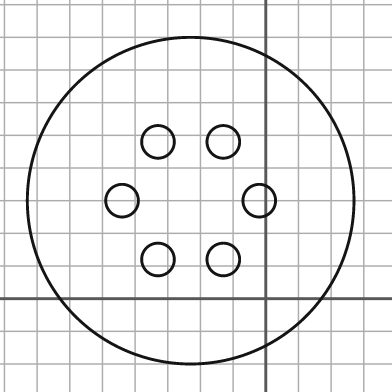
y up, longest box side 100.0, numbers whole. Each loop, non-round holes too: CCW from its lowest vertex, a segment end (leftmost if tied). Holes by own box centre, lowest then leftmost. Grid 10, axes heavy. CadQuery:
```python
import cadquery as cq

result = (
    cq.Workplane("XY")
    .moveTo(-23.0, 30.0)
    .circle(50.0)
    .moveTo(-33.0, 12.0)
    .circle(5.0)
    .moveTo(-13.0, 12.0)
    .circle(5.0)
    .moveTo(-44.0, 30.0)
    .circle(5.0)
    .moveTo(-2.0, 30.0)
    .circle(5.0)
    .moveTo(-33.0, 48.0)
    .circle(5.0)
    .moveTo(-13.0, 48.0)
    .circle(5.0)
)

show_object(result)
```